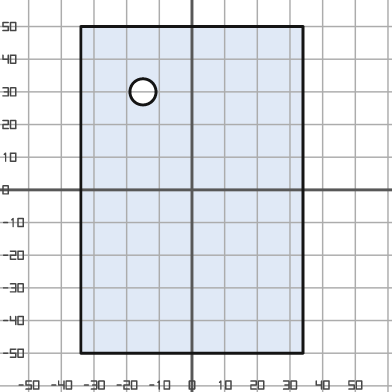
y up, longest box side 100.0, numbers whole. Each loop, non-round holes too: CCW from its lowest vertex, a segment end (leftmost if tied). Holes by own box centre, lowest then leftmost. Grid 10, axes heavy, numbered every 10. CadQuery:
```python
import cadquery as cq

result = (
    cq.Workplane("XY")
    .moveTo(-34.0, -50.0)
    .lineTo(34.0, -50.0)
    .lineTo(34.0, 50.0)
    .lineTo(-34.0, 50.0)
    .close()
    .moveTo(-15.0, 30.0)
    .circle(4.0)
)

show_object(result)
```